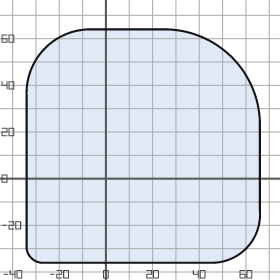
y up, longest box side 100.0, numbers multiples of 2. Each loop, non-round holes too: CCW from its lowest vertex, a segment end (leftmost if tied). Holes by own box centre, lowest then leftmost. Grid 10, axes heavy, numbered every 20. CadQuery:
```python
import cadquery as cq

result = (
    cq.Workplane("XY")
    .moveTo(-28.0, -36.0)
    .lineTo(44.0, -36.0)
    .threePointArc((60.0, -30.0), (66.0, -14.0))
    .lineTo(66.0, 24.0)
    .threePointArc((54.0, 52.0), (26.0, 64.0))
    .lineTo(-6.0, 64.0)
    .threePointArc((-26.0, 56.0), (-34.0, 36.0))
    .lineTo(-34.0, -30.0)
    .threePointArc((-32.0, -34.0), (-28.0, -36.0))
    .close()
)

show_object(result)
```